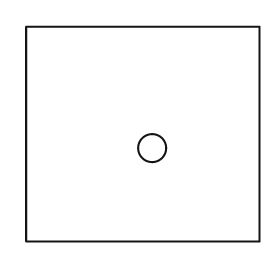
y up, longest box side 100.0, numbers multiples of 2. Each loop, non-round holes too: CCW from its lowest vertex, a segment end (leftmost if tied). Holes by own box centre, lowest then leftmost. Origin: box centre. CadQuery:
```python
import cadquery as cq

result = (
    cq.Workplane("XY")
    .moveTo(-50.0, -46.0)
    .lineTo(50.0, -46.0)
    .lineTo(50.0, 46.0)
    .lineTo(-50.0, 46.0)
    .close()
    .moveTo(4.0, -6.0)
    .circle(6.0)
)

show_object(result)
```